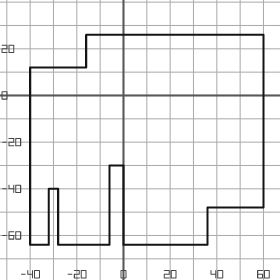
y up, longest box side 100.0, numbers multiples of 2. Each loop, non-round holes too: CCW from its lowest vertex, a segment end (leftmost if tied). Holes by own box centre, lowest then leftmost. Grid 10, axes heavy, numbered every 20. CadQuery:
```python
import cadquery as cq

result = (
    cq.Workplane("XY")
    .moveTo(-40.0, -64.0)
    .lineTo(-32.0, -64.0)
    .lineTo(-32.0, -40.0)
    .lineTo(-28.0, -40.0)
    .lineTo(-28.0, -64.0)
    .lineTo(-6.0, -64.0)
    .lineTo(-6.0, -30.0)
    .lineTo(0.0, -30.0)
    .lineTo(0.0, -64.0)
    .lineTo(36.0, -64.0)
    .lineTo(36.0, -48.0)
    .lineTo(60.0, -48.0)
    .lineTo(60.0, 26.0)
    .lineTo(-16.0, 26.0)
    .lineTo(-16.0, 12.0)
    .lineTo(-40.0, 12.0)
    .close()
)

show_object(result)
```